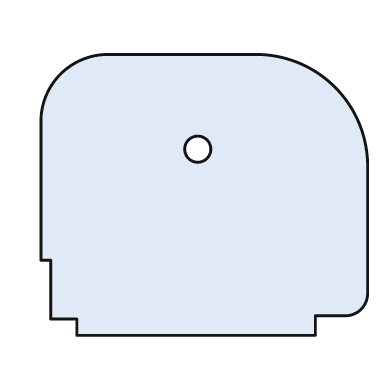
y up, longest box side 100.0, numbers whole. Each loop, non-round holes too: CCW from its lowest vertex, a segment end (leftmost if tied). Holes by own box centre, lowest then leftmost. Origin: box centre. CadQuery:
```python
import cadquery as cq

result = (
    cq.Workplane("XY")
    .moveTo(-39.0, -43.0)
    .lineTo(34.0, -43.0)
    .lineTo(34.0, -37.0)
    .lineTo(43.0, -37.0)
    .threePointArc((48.0, -35.0), (50.0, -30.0))
    .lineTo(50.0, 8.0)
    .threePointArc((40.0, 33.0), (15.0, 43.0))
    .lineTo(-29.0, 43.0)
    .threePointArc((-44.0, 37.0), (-50.0, 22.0))
    .lineTo(-50.0, -20.0)
    .lineTo(-47.0, -20.0)
    .lineTo(-47.0, -38.0)
    .lineTo(-39.0, -38.0)
    .close()
    .moveTo(-2.0, 14.0)
    .circle(4.0)
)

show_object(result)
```